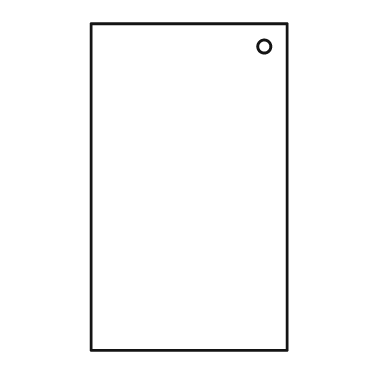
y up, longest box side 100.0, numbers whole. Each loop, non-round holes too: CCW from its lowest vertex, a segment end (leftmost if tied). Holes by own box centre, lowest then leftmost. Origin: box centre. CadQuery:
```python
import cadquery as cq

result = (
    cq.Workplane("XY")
    .moveTo(-30.0, -50.0)
    .lineTo(30.0, -50.0)
    .lineTo(30.0, 50.0)
    .lineTo(-30.0, 50.0)
    .close()
    .moveTo(23.0, 43.0)
    .circle(2.0)
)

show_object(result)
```